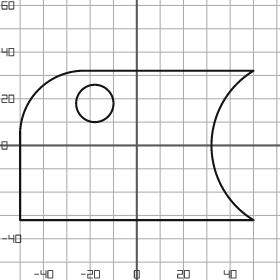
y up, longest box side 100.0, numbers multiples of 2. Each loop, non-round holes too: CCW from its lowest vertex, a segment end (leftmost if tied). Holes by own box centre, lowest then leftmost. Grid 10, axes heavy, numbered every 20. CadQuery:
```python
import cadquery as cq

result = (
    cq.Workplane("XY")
    .moveTo(-50.0, -32.0)
    .lineTo(50.0, -32.0)
    .threePointArc((32.0, 0.0), (50.0, 32.0))
    .lineTo(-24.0, 32.0)
    .threePointArc((-42.0, 24.0), (-50.0, 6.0))
    .close()
    .moveTo(-18.0, 18.0)
    .circle(8.0)
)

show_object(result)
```